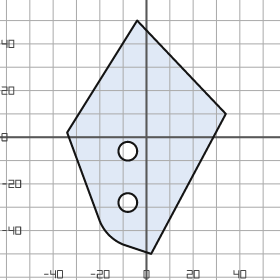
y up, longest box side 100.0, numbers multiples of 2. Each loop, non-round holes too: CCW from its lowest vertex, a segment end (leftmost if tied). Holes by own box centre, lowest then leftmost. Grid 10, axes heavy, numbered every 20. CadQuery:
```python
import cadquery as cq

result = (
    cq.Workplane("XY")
    .moveTo(2.0, -50.0)
    .lineTo(34.0, 10.0)
    .lineTo(-4.0, 50.0)
    .lineTo(-34.0, 2.0)
    .lineTo(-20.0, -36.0)
    .threePointArc((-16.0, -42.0), (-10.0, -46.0))
    .close()
    .moveTo(-8.0, -28.0)
    .circle(4.0)
    .moveTo(-8.0, -6.0)
    .circle(4.0)
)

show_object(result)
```